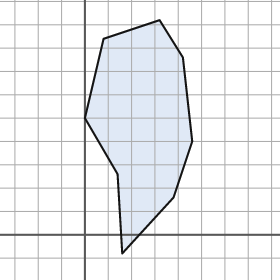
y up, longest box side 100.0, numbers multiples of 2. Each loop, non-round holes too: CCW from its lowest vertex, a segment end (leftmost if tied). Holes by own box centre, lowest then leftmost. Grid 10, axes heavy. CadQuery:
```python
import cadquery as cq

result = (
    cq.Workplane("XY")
    .moveTo(16.0, -8.0)
    .lineTo(38.0, 16.0)
    .lineTo(46.0, 40.0)
    .lineTo(42.0, 76.0)
    .lineTo(32.0, 92.0)
    .lineTo(8.0, 84.0)
    .lineTo(0.0, 50.0)
    .lineTo(14.0, 26.0)
    .close()
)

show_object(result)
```